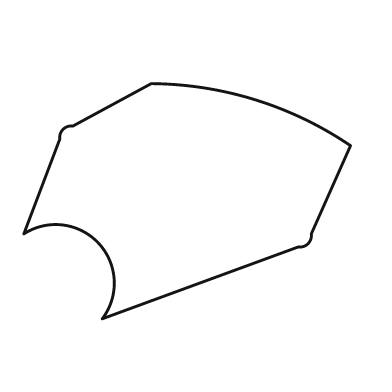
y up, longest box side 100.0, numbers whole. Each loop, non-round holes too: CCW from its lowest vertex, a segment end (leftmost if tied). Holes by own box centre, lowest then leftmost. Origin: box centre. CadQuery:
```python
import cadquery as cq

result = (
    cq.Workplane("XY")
    .moveTo(-26.0, -36.0)
    .lineTo(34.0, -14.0)
    .threePointArc((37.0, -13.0), (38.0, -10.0))
    .lineTo(50.0, 17.0)
    .threePointArc((21.0, 31.0), (-11.0, 36.0))
    .lineTo(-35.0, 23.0)
    .threePointArc((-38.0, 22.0), (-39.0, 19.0))
    .lineTo(-50.0, -10.0)
    .threePointArc((-27.0, -13.0), (-26.0, -36.0))
    .close()
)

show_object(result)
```